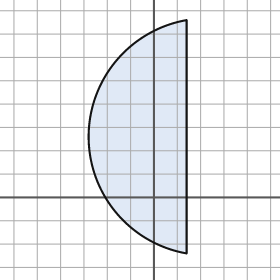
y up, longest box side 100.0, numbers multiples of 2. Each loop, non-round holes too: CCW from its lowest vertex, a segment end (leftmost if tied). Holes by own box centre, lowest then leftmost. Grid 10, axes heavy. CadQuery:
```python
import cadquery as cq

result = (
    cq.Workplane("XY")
    .moveTo(14.0, -24.0)
    .lineTo(14.0, 76.0)
    .threePointArc((-28.0, 26.0), (14.0, -24.0))
    .close()
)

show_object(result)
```